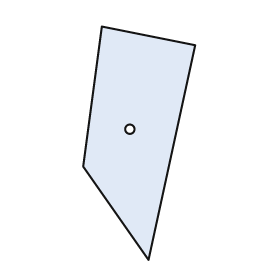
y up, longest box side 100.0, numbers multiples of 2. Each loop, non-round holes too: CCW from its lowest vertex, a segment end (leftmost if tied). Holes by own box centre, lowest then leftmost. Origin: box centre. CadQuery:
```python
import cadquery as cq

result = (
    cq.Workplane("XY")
    .moveTo(4.0, -50.0)
    .lineTo(24.0, 42.0)
    .lineTo(-16.0, 50.0)
    .lineTo(-24.0, -10.0)
    .close()
    .moveTo(-4.0, 6.0)
    .circle(2.0)
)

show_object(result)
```